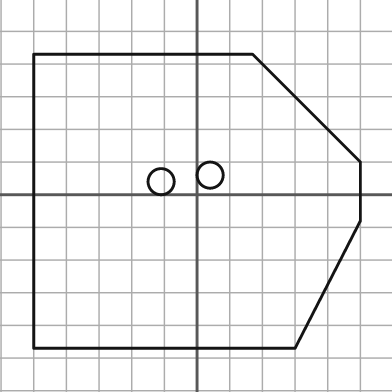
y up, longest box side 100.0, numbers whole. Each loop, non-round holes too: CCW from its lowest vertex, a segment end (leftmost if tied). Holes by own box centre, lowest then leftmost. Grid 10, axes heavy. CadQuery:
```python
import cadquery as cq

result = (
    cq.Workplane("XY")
    .moveTo(-50.0, -47.0)
    .lineTo(30.0, -47.0)
    .lineTo(50.0, -8.0)
    .lineTo(50.0, 10.0)
    .lineTo(17.0, 43.0)
    .lineTo(-50.0, 43.0)
    .close()
    .moveTo(-11.0, 4.0)
    .circle(4.0)
    .moveTo(4.0, 6.0)
    .circle(4.0)
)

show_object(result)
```